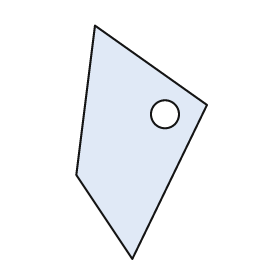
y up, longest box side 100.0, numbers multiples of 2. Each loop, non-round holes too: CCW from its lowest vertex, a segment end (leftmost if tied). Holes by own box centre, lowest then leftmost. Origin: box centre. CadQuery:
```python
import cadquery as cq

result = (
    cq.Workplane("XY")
    .moveTo(-4.0, -50.0)
    .lineTo(28.0, 16.0)
    .lineTo(-20.0, 50.0)
    .lineTo(-28.0, -14.0)
    .close()
    .moveTo(10.0, 12.0)
    .circle(6.0)
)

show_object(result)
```